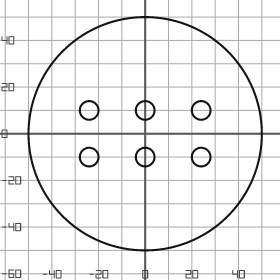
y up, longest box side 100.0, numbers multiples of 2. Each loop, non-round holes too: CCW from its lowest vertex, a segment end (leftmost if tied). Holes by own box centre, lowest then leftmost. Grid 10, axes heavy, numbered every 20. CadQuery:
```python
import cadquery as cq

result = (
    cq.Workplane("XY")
    .moveTo(0.0, 0.0)
    .circle(50.0)
    .moveTo(-24.0, -10.0)
    .circle(4.0)
    .moveTo(0.0, -10.0)
    .circle(4.0)
    .moveTo(24.0, -10.0)
    .circle(4.0)
    .moveTo(-24.0, 10.0)
    .circle(4.0)
    .moveTo(0.0, 10.0)
    .circle(4.0)
    .moveTo(24.0, 10.0)
    .circle(4.0)
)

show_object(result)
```